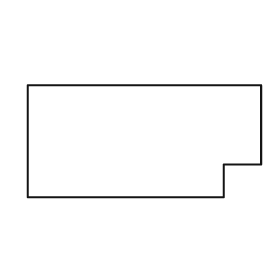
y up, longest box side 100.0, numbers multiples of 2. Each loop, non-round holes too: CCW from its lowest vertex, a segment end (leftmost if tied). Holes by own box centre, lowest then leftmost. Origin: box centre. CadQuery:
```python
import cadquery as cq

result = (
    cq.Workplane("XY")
    .moveTo(-50.0, -24.0)
    .lineTo(34.0, -24.0)
    .lineTo(34.0, -10.0)
    .lineTo(50.0, -10.0)
    .lineTo(50.0, 24.0)
    .lineTo(-50.0, 24.0)
    .close()
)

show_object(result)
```